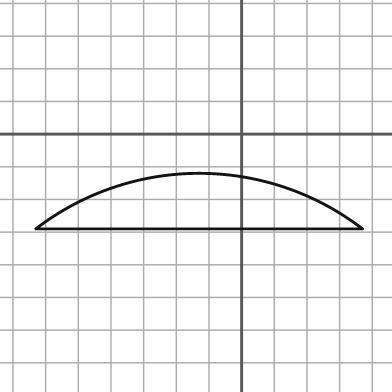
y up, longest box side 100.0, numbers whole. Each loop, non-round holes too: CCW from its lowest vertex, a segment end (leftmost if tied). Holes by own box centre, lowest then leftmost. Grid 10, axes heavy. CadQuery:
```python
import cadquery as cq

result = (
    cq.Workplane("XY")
    .moveTo(-63.0, -29.0)
    .lineTo(37.0, -29.0)
    .threePointArc((-13.0, -12.0), (-63.0, -29.0))
    .close()
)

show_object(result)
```